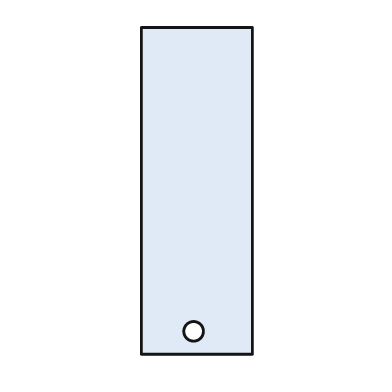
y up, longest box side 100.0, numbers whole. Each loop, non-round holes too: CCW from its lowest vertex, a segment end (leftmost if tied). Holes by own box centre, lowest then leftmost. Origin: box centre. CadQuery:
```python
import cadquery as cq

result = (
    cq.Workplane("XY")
    .moveTo(-17.0, -50.0)
    .lineTo(17.0, -50.0)
    .lineTo(17.0, 50.0)
    .lineTo(-17.0, 50.0)
    .close()
    .moveTo(-1.0, -43.0)
    .circle(3.0)
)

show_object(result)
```